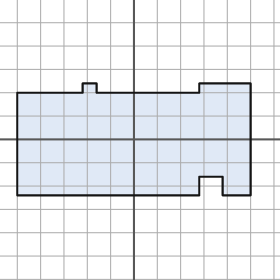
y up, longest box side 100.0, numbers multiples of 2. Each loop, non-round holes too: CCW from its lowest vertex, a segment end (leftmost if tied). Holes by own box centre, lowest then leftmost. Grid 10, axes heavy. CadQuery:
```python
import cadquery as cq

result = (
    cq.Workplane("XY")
    .moveTo(-50.0, -24.0)
    .lineTo(28.0, -24.0)
    .lineTo(28.0, -16.0)
    .lineTo(38.0, -16.0)
    .lineTo(38.0, -24.0)
    .lineTo(50.0, -24.0)
    .lineTo(50.0, 24.0)
    .lineTo(28.0, 24.0)
    .lineTo(28.0, 20.0)
    .lineTo(-16.0, 20.0)
    .lineTo(-16.0, 24.0)
    .lineTo(-22.0, 24.0)
    .lineTo(-22.0, 20.0)
    .lineTo(-50.0, 20.0)
    .close()
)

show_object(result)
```